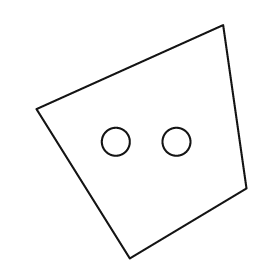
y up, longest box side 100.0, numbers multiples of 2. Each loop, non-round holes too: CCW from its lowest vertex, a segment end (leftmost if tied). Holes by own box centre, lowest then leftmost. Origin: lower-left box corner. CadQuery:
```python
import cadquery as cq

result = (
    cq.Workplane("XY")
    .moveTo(40.0, 0.0)
    .lineTo(90.0, 30.0)
    .lineTo(80.0, 100.0)
    .lineTo(0.0, 64.0)
    .close()
    .moveTo(34.0, 50.0)
    .circle(6.0)
    .moveTo(60.0, 50.0)
    .circle(6.0)
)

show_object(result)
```